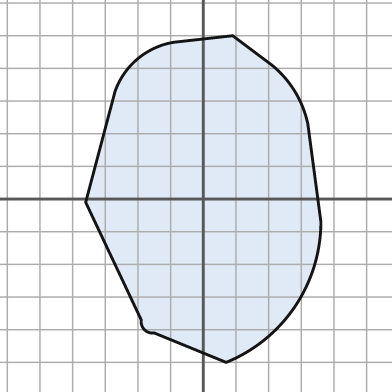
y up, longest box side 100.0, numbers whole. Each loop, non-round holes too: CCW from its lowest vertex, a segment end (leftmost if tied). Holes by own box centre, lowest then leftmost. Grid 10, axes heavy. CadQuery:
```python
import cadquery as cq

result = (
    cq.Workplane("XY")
    .moveTo(7.0, -50.0)
    .threePointArc((28.0, -33.0), (36.0, -7.0))
    .lineTo(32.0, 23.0)
    .threePointArc((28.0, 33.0), (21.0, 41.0))
    .lineTo(9.0, 50.0)
    .lineTo(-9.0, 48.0)
    .threePointArc((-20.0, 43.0), (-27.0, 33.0))
    .lineTo(-36.0, -1.0)
    .lineTo(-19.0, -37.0)
    .threePointArc((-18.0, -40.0), (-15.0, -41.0))
    .close()
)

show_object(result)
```